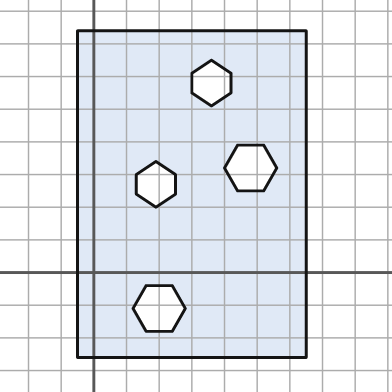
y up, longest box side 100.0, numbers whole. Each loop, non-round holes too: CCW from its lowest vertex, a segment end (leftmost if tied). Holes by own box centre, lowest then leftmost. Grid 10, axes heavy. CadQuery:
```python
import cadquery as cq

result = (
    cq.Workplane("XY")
    .moveTo(-5.0, -26.0)
    .lineTo(65.0, -26.0)
    .lineTo(65.0, 74.0)
    .lineTo(-5.0, 74.0)
    .close()
    .moveTo(16.0, -18.0)
    .lineTo(24.0, -18.0)
    .lineTo(28.0, -11.0)
    .lineTo(24.0, -4.0)
    .lineTo(16.0, -4.0)
    .lineTo(12.0, -11.0)
    .close()
    .moveTo(19.0, 20.0)
    .lineTo(25.0, 24.0)
    .lineTo(25.0, 30.0)
    .lineTo(19.0, 34.0)
    .lineTo(13.0, 30.0)
    .lineTo(13.0, 24.0)
    .close()
    .moveTo(44.0, 25.0)
    .lineTo(52.0, 25.0)
    .lineTo(56.0, 32.0)
    .lineTo(52.0, 39.0)
    .lineTo(44.0, 39.0)
    .lineTo(40.0, 32.0)
    .close()
    .moveTo(36.0, 51.0)
    .lineTo(42.0, 55.0)
    .lineTo(42.0, 61.0)
    .lineTo(36.0, 65.0)
    .lineTo(30.0, 61.0)
    .lineTo(30.0, 55.0)
    .close()
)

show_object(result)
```